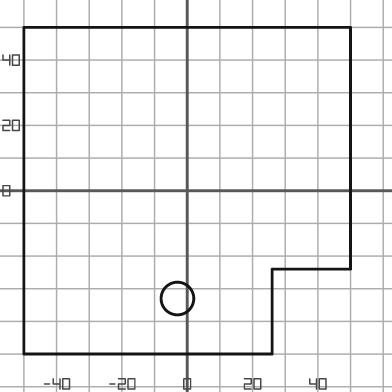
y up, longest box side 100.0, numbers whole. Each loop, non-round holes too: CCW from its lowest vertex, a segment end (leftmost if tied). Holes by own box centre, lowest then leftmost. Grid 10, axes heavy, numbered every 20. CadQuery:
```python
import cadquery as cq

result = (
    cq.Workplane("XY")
    .moveTo(-50.0, -50.0)
    .lineTo(26.0, -50.0)
    .lineTo(26.0, -24.0)
    .lineTo(50.0, -24.0)
    .lineTo(50.0, 50.0)
    .lineTo(-50.0, 50.0)
    .close()
    .moveTo(-3.0, -33.0)
    .circle(5.0)
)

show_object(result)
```